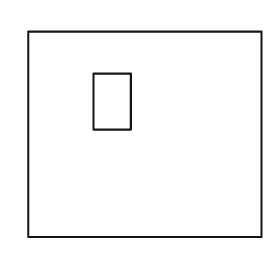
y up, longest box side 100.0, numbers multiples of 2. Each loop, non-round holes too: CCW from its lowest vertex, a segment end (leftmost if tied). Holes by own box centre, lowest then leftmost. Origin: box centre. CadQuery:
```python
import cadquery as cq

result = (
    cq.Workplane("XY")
    .moveTo(-50.0, -44.0)
    .lineTo(50.0, -44.0)
    .lineTo(50.0, 44.0)
    .lineTo(-50.0, 44.0)
    .close()
    .moveTo(-22.0, 2.0)
    .lineTo(-6.0, 2.0)
    .lineTo(-6.0, 26.0)
    .lineTo(-22.0, 26.0)
    .close()
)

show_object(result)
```